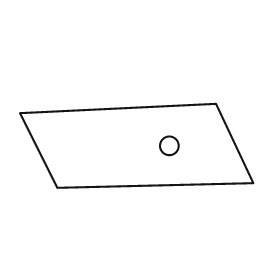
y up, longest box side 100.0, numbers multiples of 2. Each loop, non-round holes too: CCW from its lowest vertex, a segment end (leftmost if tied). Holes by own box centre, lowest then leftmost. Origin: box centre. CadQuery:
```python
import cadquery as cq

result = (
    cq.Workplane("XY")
    .moveTo(-34.0, -18.0)
    .lineTo(50.0, -16.0)
    .lineTo(34.0, 18.0)
    .lineTo(-50.0, 14.0)
    .close()
    .moveTo(14.0, 0.0)
    .circle(4.0)
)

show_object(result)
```